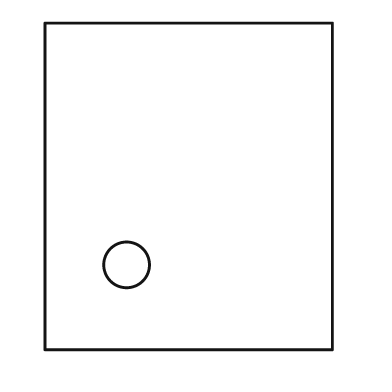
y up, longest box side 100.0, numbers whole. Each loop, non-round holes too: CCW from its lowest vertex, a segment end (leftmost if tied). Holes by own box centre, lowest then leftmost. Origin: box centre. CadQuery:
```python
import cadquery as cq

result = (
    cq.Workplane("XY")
    .moveTo(-44.0, -50.0)
    .lineTo(44.0, -50.0)
    .lineTo(44.0, 50.0)
    .lineTo(-44.0, 50.0)
    .close()
    .moveTo(-19.0, -24.0)
    .circle(7.0)
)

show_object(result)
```